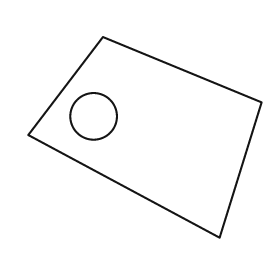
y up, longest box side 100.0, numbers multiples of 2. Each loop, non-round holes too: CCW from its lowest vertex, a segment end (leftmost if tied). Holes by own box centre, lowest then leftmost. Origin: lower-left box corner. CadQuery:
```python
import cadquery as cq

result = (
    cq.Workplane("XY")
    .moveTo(82.0, 0.0)
    .lineTo(100.0, 58.0)
    .lineTo(32.0, 86.0)
    .lineTo(0.0, 44.0)
    .close()
    .moveTo(28.0, 52.0)
    .circle(10.0)
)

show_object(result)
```